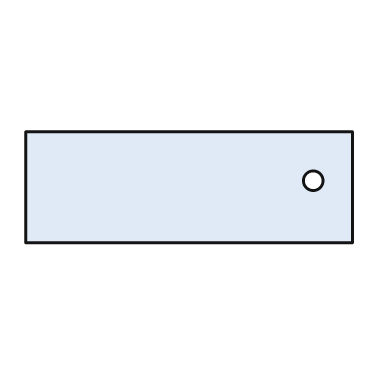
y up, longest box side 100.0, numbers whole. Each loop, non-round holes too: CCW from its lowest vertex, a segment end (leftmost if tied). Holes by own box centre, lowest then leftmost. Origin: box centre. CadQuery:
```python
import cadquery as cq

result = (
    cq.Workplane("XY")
    .moveTo(-50.0, -17.0)
    .lineTo(50.0, -17.0)
    .lineTo(50.0, 17.0)
    .lineTo(-50.0, 17.0)
    .close()
    .moveTo(38.0, 2.0)
    .circle(3.0)
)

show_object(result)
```